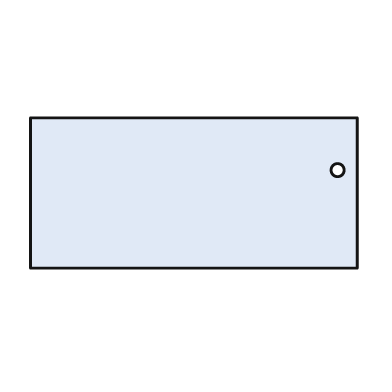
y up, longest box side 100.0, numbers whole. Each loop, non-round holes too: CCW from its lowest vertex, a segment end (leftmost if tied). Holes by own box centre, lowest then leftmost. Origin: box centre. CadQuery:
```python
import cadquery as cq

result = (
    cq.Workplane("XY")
    .moveTo(-50.0, -23.0)
    .lineTo(50.0, -23.0)
    .lineTo(50.0, 23.0)
    .lineTo(-50.0, 23.0)
    .close()
    .moveTo(44.0, 7.0)
    .circle(2.0)
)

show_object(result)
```